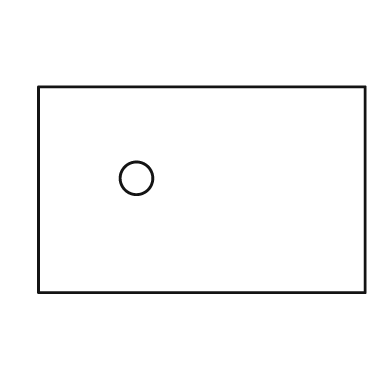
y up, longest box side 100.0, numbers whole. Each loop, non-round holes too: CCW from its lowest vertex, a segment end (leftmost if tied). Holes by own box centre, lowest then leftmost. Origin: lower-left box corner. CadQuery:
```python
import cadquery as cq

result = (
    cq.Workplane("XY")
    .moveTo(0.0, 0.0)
    .lineTo(100.0, 0.0)
    .lineTo(100.0, 63.0)
    .lineTo(0.0, 63.0)
    .close()
    .moveTo(30.0, 35.0)
    .circle(5.0)
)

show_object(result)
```